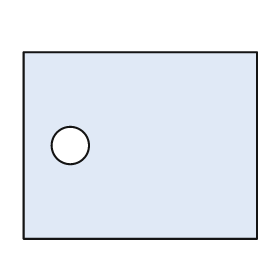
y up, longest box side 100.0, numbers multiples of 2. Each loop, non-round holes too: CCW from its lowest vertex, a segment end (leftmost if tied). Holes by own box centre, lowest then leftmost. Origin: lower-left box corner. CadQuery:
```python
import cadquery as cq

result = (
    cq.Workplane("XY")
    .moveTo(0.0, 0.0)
    .lineTo(100.0, 0.0)
    .lineTo(100.0, 80.0)
    .lineTo(0.0, 80.0)
    .close()
    .moveTo(20.0, 40.0)
    .circle(8.0)
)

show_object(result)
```